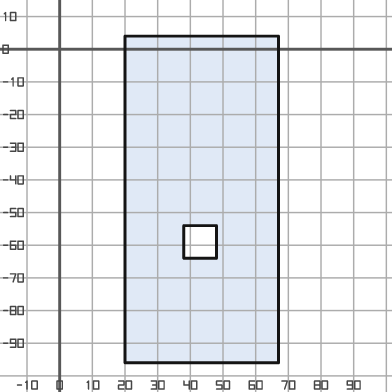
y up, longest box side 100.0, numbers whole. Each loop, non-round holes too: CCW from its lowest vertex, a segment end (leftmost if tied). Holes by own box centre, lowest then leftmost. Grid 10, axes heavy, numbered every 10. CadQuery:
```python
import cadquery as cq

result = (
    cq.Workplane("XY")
    .moveTo(20.0, -96.0)
    .lineTo(67.0, -96.0)
    .lineTo(67.0, 4.0)
    .lineTo(20.0, 4.0)
    .close()
    .moveTo(38.0, -64.0)
    .lineTo(48.0, -64.0)
    .lineTo(48.0, -54.0)
    .lineTo(38.0, -54.0)
    .close()
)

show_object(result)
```